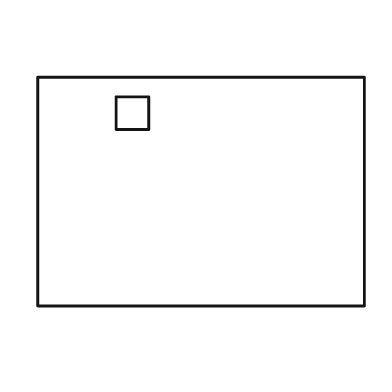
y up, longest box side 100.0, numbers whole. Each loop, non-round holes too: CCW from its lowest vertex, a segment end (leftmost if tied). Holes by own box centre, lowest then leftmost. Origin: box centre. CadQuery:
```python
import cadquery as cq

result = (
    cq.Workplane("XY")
    .moveTo(-50.0, -35.0)
    .lineTo(50.0, -35.0)
    .lineTo(50.0, 35.0)
    .lineTo(-50.0, 35.0)
    .close()
    .moveTo(-26.0, 19.0)
    .lineTo(-16.0, 19.0)
    .lineTo(-16.0, 29.0)
    .lineTo(-26.0, 29.0)
    .close()
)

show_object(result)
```